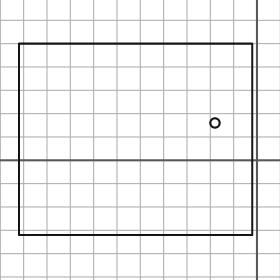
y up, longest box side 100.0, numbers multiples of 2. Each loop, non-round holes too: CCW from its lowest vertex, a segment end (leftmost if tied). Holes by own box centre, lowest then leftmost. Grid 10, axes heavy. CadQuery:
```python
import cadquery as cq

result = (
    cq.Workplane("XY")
    .moveTo(-102.0, -32.0)
    .lineTo(-2.0, -32.0)
    .lineTo(-2.0, 50.0)
    .lineTo(-102.0, 50.0)
    .close()
    .moveTo(-18.0, 16.0)
    .circle(2.0)
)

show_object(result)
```